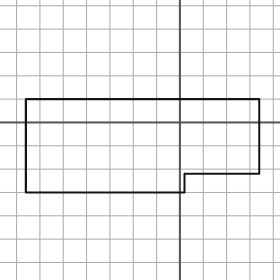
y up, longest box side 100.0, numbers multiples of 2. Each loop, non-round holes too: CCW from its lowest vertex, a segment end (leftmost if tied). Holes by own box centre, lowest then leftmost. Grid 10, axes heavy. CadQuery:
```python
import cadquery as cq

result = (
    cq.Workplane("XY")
    .moveTo(-66.0, -30.0)
    .lineTo(2.0, -30.0)
    .lineTo(2.0, -22.0)
    .lineTo(34.0, -22.0)
    .lineTo(34.0, 10.0)
    .lineTo(-66.0, 10.0)
    .close()
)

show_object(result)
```